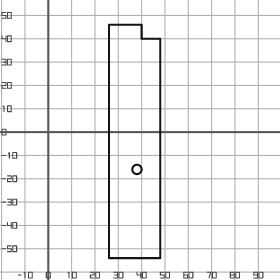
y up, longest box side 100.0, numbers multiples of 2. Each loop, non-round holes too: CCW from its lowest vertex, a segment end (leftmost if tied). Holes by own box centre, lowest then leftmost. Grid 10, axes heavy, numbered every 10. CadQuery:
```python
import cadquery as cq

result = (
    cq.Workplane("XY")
    .moveTo(26.0, -54.0)
    .lineTo(48.0, -54.0)
    .lineTo(48.0, 40.0)
    .lineTo(40.0, 40.0)
    .lineTo(40.0, 46.0)
    .lineTo(26.0, 46.0)
    .close()
    .moveTo(38.0, -16.0)
    .circle(2.0)
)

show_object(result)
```